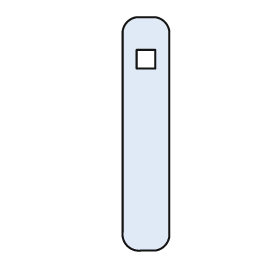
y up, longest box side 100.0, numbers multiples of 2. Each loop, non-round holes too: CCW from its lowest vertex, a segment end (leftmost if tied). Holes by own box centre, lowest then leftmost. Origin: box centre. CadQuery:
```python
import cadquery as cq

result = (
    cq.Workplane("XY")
    .moveTo(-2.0, -50.0)
    .lineTo(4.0, -50.0)
    .threePointArc((8.0, -48.0), (10.0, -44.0))
    .lineTo(10.0, 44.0)
    .threePointArc((8.0, 48.0), (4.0, 50.0))
    .lineTo(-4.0, 50.0)
    .threePointArc((-8.0, 48.0), (-10.0, 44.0))
    .lineTo(-10.0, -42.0)
    .threePointArc((-8.0, -48.0), (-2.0, -50.0))
    .close()
    .moveTo(-4.0, 28.0)
    .lineTo(4.0, 28.0)
    .lineTo(4.0, 36.0)
    .lineTo(-4.0, 36.0)
    .close()
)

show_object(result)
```